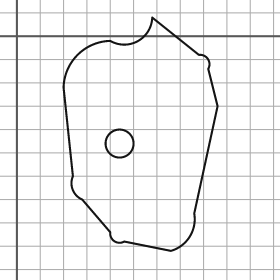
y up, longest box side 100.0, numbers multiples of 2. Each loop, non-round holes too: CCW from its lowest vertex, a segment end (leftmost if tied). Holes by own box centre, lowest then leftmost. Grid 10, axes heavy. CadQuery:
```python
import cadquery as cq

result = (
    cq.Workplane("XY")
    .moveTo(66.0, -92.0)
    .threePointArc((74.0, -86.0), (76.0, -76.0))
    .lineTo(86.0, -30.0)
    .lineTo(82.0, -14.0)
    .threePointArc((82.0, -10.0), (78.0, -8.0))
    .lineTo(58.0, 8.0)
    .threePointArc((52.0, -2.0), (40.0, -2.0))
    .threePointArc((26.0, -8.0), (20.0, -22.0))
    .lineTo(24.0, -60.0)
    .threePointArc((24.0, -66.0), (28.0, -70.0))
    .lineTo(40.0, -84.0)
    .threePointArc((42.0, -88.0), (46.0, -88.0))
    .close()
    .moveTo(44.0, -46.0)
    .circle(6.0)
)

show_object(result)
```